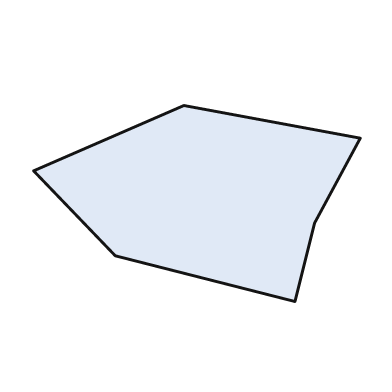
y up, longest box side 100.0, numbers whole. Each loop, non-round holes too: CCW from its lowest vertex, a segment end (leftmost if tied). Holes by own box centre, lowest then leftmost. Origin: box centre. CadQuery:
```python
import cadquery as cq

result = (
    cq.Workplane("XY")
    .moveTo(30.0, -30.0)
    .lineTo(36.0, -6.0)
    .lineTo(50.0, 20.0)
    .lineTo(-4.0, 30.0)
    .lineTo(-50.0, 10.0)
    .lineTo(-25.0, -16.0)
    .close()
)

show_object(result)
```